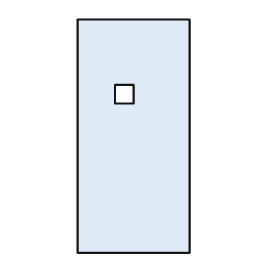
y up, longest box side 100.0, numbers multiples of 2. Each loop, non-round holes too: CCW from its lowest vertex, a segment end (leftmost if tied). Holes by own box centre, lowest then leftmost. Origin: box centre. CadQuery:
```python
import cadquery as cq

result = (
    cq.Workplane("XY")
    .moveTo(-24.0, -50.0)
    .lineTo(24.0, -50.0)
    .lineTo(24.0, 50.0)
    .lineTo(-24.0, 50.0)
    .close()
    .moveTo(-8.0, 14.0)
    .lineTo(0.0, 14.0)
    .lineTo(0.0, 22.0)
    .lineTo(-8.0, 22.0)
    .close()
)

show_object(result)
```